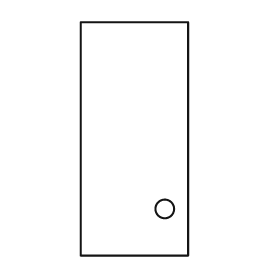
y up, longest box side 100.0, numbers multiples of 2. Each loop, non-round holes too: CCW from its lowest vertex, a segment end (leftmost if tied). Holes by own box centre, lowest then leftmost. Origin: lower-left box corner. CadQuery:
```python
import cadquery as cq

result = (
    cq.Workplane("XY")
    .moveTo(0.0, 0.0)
    .lineTo(46.0, 0.0)
    .lineTo(46.0, 100.0)
    .lineTo(0.0, 100.0)
    .close()
    .moveTo(36.0, 20.0)
    .circle(4.0)
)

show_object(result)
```